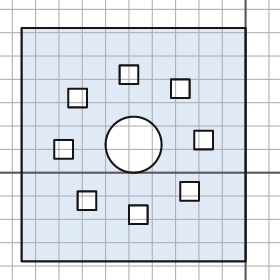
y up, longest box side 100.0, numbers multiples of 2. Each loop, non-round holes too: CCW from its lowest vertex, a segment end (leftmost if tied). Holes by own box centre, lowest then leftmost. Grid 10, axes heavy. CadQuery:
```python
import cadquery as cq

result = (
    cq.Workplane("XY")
    .moveTo(-96.0, -38.0)
    .lineTo(0.0, -38.0)
    .lineTo(0.0, 62.0)
    .lineTo(-96.0, 62.0)
    .close()
    .moveTo(-50.0, -22.0)
    .lineTo(-42.0, -22.0)
    .lineTo(-42.0, -14.0)
    .lineTo(-50.0, -14.0)
    .close()
    .moveTo(-72.0, -16.0)
    .lineTo(-64.0, -16.0)
    .lineTo(-64.0, -8.0)
    .lineTo(-72.0, -8.0)
    .close()
    .moveTo(-28.0, -12.0)
    .lineTo(-20.0, -12.0)
    .lineTo(-20.0, -4.0)
    .lineTo(-28.0, -4.0)
    .close()
    .moveTo(-82.0, 6.0)
    .lineTo(-74.0, 6.0)
    .lineTo(-74.0, 14.0)
    .lineTo(-82.0, 14.0)
    .close()
    .moveTo(-48.0, 12.0)
    .circle(12.0)
    .moveTo(-22.0, 10.0)
    .lineTo(-14.0, 10.0)
    .lineTo(-14.0, 18.0)
    .lineTo(-22.0, 18.0)
    .close()
    .moveTo(-76.0, 28.0)
    .lineTo(-68.0, 28.0)
    .lineTo(-68.0, 36.0)
    .lineTo(-76.0, 36.0)
    .close()
    .moveTo(-32.0, 32.0)
    .lineTo(-24.0, 32.0)
    .lineTo(-24.0, 40.0)
    .lineTo(-32.0, 40.0)
    .close()
    .moveTo(-54.0, 38.0)
    .lineTo(-46.0, 38.0)
    .lineTo(-46.0, 46.0)
    .lineTo(-54.0, 46.0)
    .close()
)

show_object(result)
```